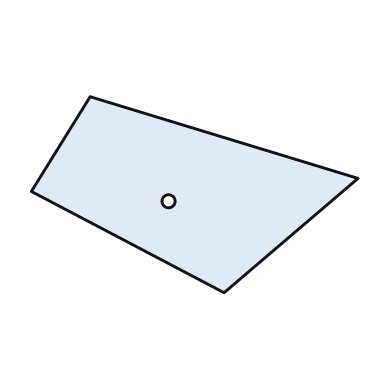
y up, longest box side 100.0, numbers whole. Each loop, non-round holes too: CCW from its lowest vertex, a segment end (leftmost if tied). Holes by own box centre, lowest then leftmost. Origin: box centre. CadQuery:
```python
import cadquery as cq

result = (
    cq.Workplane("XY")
    .moveTo(9.0, -30.0)
    .lineTo(50.0, 5.0)
    .lineTo(-32.0, 30.0)
    .lineTo(-50.0, 1.0)
    .close()
    .moveTo(-8.0, -2.0)
    .circle(2.0)
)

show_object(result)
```